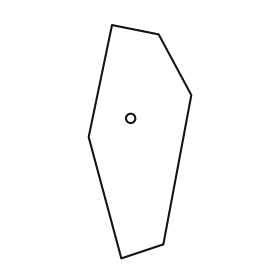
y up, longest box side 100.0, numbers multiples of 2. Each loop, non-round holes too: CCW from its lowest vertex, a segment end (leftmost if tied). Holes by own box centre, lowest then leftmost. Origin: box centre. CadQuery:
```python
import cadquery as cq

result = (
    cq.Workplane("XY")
    .moveTo(-8.0, -50.0)
    .lineTo(10.0, -44.0)
    .lineTo(22.0, 20.0)
    .lineTo(8.0, 46.0)
    .lineTo(-12.0, 50.0)
    .lineTo(-22.0, 2.0)
    .close()
    .moveTo(-4.0, 10.0)
    .circle(2.0)
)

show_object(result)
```